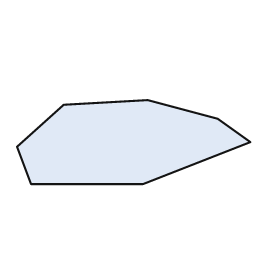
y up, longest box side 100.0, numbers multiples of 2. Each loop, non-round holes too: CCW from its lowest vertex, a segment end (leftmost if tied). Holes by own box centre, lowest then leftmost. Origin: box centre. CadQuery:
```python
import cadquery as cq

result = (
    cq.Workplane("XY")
    .moveTo(-44.0, -18.0)
    .lineTo(4.0, -18.0)
    .lineTo(50.0, 0.0)
    .lineTo(36.0, 10.0)
    .lineTo(6.0, 18.0)
    .lineTo(-30.0, 16.0)
    .lineTo(-50.0, -2.0)
    .close()
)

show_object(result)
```